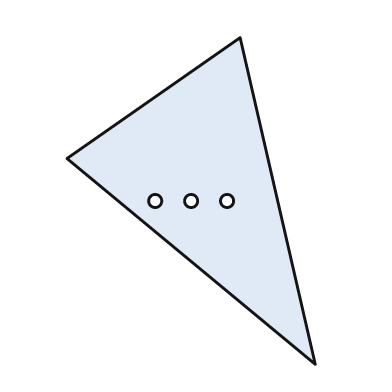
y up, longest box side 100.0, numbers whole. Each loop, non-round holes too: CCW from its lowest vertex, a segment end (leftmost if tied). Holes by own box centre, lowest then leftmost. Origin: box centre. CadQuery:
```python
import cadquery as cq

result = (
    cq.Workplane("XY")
    .moveTo(38.0, -50.0)
    .lineTo(15.0, 50.0)
    .lineTo(-38.0, 13.0)
    .close()
    .moveTo(-11.0, 0.0)
    .circle(2.0)
    .moveTo(0.0, 0.0)
    .circle(2.0)
    .moveTo(11.0, 0.0)
    .circle(2.0)
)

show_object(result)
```